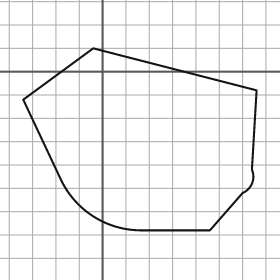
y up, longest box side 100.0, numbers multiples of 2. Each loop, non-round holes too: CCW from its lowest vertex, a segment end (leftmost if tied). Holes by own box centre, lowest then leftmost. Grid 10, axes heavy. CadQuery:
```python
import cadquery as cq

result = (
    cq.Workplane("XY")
    .moveTo(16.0, -68.0)
    .lineTo(46.0, -68.0)
    .lineTo(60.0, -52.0)
    .threePointArc((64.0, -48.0), (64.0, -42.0))
    .lineTo(66.0, -8.0)
    .lineTo(-4.0, 10.0)
    .lineTo(-34.0, -12.0)
    .lineTo(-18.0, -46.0)
    .threePointArc((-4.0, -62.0), (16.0, -68.0))
    .close()
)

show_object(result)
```